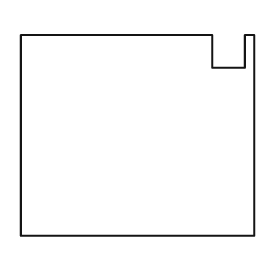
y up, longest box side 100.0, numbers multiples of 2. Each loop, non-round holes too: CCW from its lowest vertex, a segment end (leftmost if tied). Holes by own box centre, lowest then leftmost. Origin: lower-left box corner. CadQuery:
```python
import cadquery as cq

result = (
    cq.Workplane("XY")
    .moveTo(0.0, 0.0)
    .lineTo(100.0, 0.0)
    .lineTo(100.0, 86.0)
    .lineTo(96.0, 86.0)
    .lineTo(96.0, 72.0)
    .lineTo(82.0, 72.0)
    .lineTo(82.0, 86.0)
    .lineTo(0.0, 86.0)
    .close()
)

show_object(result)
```